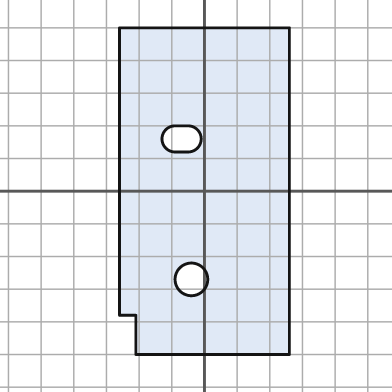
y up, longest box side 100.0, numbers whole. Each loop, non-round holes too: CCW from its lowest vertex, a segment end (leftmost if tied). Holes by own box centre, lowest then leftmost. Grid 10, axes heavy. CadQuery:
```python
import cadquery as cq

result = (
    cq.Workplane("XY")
    .moveTo(-21.0, -50.0)
    .lineTo(26.0, -50.0)
    .lineTo(26.0, 50.0)
    .lineTo(-26.0, 50.0)
    .lineTo(-26.0, -38.0)
    .lineTo(-21.0, -38.0)
    .close()
    .moveTo(-4.0, -27.0)
    .circle(5.0)
    .moveTo(-9.0, 12.0)
    .lineTo(-5.0, 12.0)
    .threePointArc((-1.0, 16.0), (-5.0, 20.0))
    .lineTo(-9.0, 20.0)
    .threePointArc((-13.0, 16.0), (-9.0, 12.0))
    .close()
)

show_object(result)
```